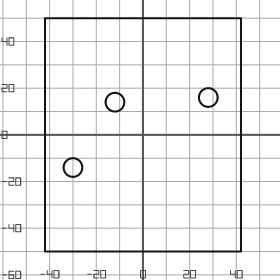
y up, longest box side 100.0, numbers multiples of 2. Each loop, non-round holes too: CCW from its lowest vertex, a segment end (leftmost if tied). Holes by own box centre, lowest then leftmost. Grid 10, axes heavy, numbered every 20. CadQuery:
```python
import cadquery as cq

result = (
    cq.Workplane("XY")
    .moveTo(-42.0, -50.0)
    .lineTo(42.0, -50.0)
    .lineTo(42.0, 50.0)
    .lineTo(-42.0, 50.0)
    .close()
    .moveTo(-30.0, -14.0)
    .circle(4.0)
    .moveTo(-12.0, 14.0)
    .circle(4.0)
    .moveTo(28.0, 16.0)
    .circle(4.0)
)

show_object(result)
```